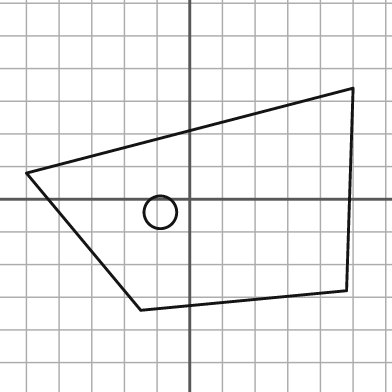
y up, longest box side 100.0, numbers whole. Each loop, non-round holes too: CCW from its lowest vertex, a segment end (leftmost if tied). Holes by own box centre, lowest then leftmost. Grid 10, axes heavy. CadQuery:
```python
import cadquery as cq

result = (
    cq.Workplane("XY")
    .moveTo(-15.0, -34.0)
    .lineTo(48.0, -28.0)
    .lineTo(50.0, 34.0)
    .lineTo(-50.0, 8.0)
    .close()
    .moveTo(-9.0, -4.0)
    .circle(5.0)
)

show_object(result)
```